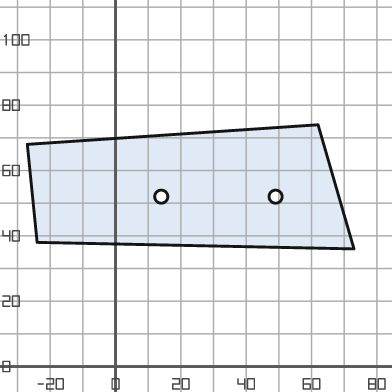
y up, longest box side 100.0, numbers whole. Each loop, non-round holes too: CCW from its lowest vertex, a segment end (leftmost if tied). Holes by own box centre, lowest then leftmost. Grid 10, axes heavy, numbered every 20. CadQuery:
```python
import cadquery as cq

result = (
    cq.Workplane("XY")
    .moveTo(73.0, 36.0)
    .lineTo(62.0, 74.0)
    .lineTo(-27.0, 68.0)
    .lineTo(-24.0, 38.0)
    .close()
    .moveTo(14.0, 52.0)
    .circle(2.0)
    .moveTo(49.0, 52.0)
    .circle(2.0)
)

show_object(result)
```